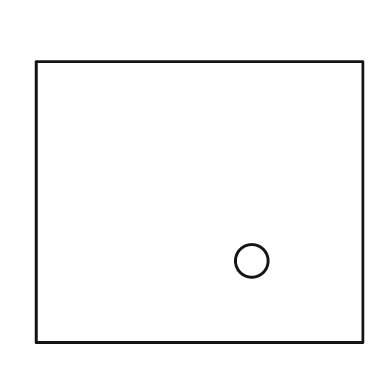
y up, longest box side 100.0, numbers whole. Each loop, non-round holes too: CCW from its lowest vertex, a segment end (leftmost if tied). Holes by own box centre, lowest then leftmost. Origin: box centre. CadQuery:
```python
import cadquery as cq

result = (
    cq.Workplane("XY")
    .moveTo(-50.0, -43.0)
    .lineTo(50.0, -43.0)
    .lineTo(50.0, 43.0)
    .lineTo(-50.0, 43.0)
    .close()
    .moveTo(16.0, -18.0)
    .circle(5.0)
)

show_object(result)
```